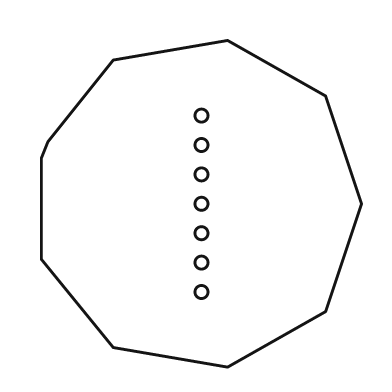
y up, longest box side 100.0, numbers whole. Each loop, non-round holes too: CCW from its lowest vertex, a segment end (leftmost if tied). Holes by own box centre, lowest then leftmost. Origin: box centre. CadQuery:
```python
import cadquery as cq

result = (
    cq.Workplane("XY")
    .moveTo(8.0, -50.0)
    .lineTo(38.0, -33.0)
    .lineTo(49.0, 0.0)
    .lineTo(38.0, 33.0)
    .lineTo(8.0, 50.0)
    .lineTo(-27.0, 44.0)
    .lineTo(-47.0, 19.0)
    .lineTo(-49.0, 14.0)
    .lineTo(-49.0, -17.0)
    .lineTo(-27.0, -44.0)
    .close()
    .moveTo(0.0, -27.0)
    .circle(2.0)
    .moveTo(0.0, -18.0)
    .circle(2.0)
    .moveTo(0.0, -9.0)
    .circle(2.0)
    .moveTo(0.0, 0.0)
    .circle(2.0)
    .moveTo(0.0, 9.0)
    .circle(2.0)
    .moveTo(0.0, 18.0)
    .circle(2.0)
    .moveTo(0.0, 27.0)
    .circle(2.0)
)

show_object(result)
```